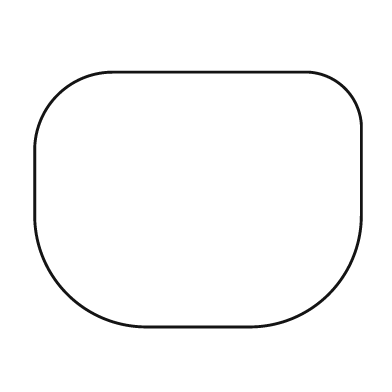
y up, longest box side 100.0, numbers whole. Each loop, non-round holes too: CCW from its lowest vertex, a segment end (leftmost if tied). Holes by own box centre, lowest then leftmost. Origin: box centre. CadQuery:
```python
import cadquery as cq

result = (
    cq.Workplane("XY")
    .moveTo(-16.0, -39.0)
    .lineTo(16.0, -39.0)
    .threePointArc((40.0, -29.0), (50.0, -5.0))
    .lineTo(50.0, 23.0)
    .threePointArc((45.0, 34.0), (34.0, 39.0))
    .lineTo(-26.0, 39.0)
    .threePointArc((-43.0, 32.0), (-50.0, 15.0))
    .lineTo(-50.0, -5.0)
    .threePointArc((-40.0, -29.0), (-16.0, -39.0))
    .close()
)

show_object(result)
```